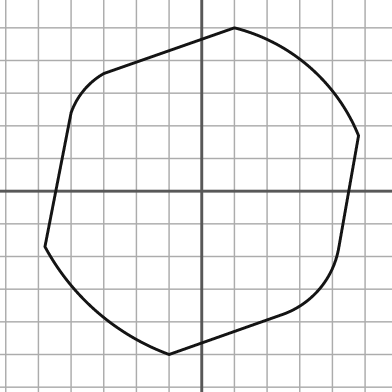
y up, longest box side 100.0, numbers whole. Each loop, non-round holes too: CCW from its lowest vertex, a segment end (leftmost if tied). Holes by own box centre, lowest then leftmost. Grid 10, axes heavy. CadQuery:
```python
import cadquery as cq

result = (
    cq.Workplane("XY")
    .moveTo(-10.0, -50.0)
    .lineTo(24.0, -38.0)
    .threePointArc((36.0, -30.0), (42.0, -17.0))
    .lineTo(48.0, 17.0)
    .threePointArc((33.0, 38.0), (10.0, 50.0))
    .lineTo(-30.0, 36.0)
    .threePointArc((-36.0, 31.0), (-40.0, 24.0))
    .lineTo(-48.0, -17.0)
    .threePointArc((-32.0, -37.0), (-10.0, -50.0))
    .close()
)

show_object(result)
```